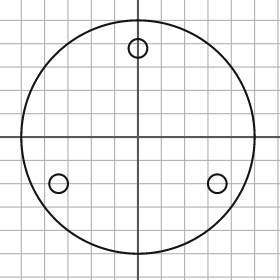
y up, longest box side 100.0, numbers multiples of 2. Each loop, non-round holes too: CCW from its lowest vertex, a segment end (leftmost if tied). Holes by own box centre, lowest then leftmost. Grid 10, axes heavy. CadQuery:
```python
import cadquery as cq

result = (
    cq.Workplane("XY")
    .moveTo(0.0, 0.0)
    .circle(50.0)
    .moveTo(-34.0, -20.0)
    .circle(4.0)
    .moveTo(34.0, -20.0)
    .circle(4.0)
    .moveTo(0.0, 38.0)
    .circle(4.0)
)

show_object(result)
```